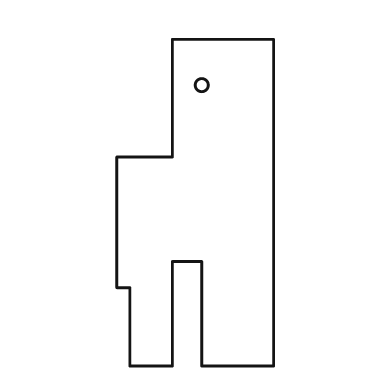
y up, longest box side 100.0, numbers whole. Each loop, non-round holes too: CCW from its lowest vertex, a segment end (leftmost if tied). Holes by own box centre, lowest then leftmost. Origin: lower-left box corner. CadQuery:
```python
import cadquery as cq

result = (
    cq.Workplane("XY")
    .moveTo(4.0, 0.0)
    .lineTo(17.0, 0.0)
    .lineTo(17.0, 32.0)
    .lineTo(26.0, 32.0)
    .lineTo(26.0, 0.0)
    .lineTo(48.0, 0.0)
    .lineTo(48.0, 100.0)
    .lineTo(17.0, 100.0)
    .lineTo(17.0, 64.0)
    .lineTo(0.0, 64.0)
    .lineTo(0.0, 24.0)
    .lineTo(4.0, 24.0)
    .close()
    .moveTo(26.0, 86.0)
    .circle(2.0)
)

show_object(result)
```